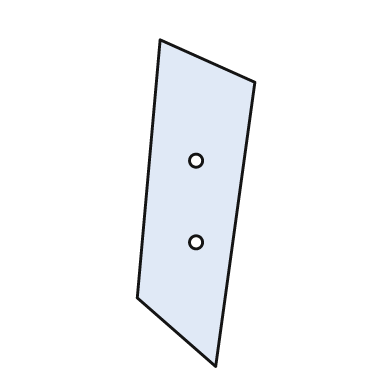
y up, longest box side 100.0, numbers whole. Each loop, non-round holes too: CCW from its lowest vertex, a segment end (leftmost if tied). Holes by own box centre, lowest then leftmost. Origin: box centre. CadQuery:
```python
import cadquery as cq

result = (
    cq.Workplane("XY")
    .moveTo(6.0, -50.0)
    .lineTo(18.0, 37.0)
    .lineTo(-11.0, 50.0)
    .lineTo(-18.0, -29.0)
    .close()
    .moveTo(0.0, -12.0)
    .circle(2.0)
    .moveTo(0.0, 13.0)
    .circle(2.0)
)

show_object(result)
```